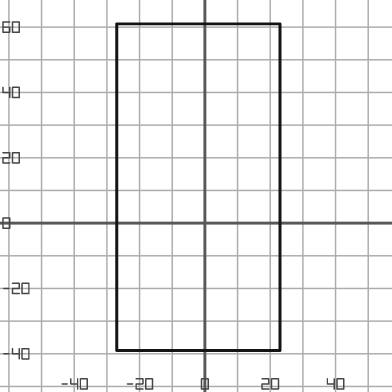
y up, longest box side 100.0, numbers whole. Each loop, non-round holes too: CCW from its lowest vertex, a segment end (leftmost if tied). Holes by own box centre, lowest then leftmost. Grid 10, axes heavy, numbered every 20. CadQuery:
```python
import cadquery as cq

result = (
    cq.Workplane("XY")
    .moveTo(-27.0, -39.0)
    .lineTo(23.0, -39.0)
    .lineTo(23.0, 61.0)
    .lineTo(-27.0, 61.0)
    .close()
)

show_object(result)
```